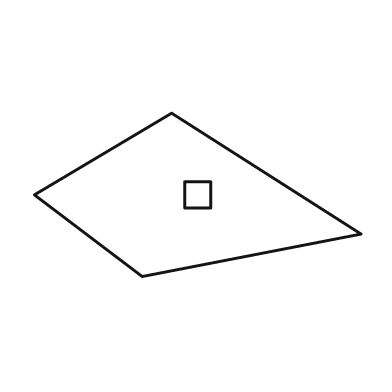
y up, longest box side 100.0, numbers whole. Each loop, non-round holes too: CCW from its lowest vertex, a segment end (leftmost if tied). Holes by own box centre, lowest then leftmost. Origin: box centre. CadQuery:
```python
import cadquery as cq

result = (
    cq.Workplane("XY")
    .moveTo(-17.0, -25.0)
    .lineTo(50.0, -12.0)
    .lineTo(-8.0, 25.0)
    .lineTo(-50.0, 0.0)
    .close()
    .moveTo(-4.0, -4.0)
    .lineTo(4.0, -4.0)
    .lineTo(4.0, 4.0)
    .lineTo(-4.0, 4.0)
    .close()
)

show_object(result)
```